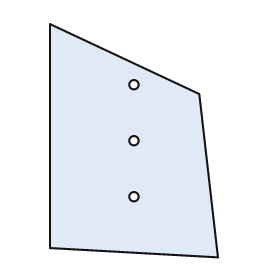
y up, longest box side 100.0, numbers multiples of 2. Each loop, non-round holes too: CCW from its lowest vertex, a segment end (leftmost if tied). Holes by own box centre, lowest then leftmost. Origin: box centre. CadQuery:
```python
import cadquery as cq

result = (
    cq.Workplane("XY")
    .moveTo(36.0, -50.0)
    .lineTo(28.0, 20.0)
    .lineTo(-36.0, 50.0)
    .lineTo(-36.0, -46.0)
    .close()
    .moveTo(0.0, -24.0)
    .circle(2.0)
    .moveTo(0.0, 0.0)
    .circle(2.0)
    .moveTo(0.0, 24.0)
    .circle(2.0)
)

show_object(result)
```